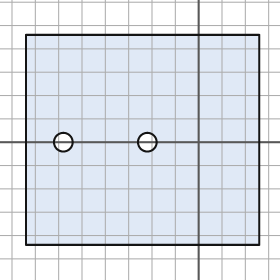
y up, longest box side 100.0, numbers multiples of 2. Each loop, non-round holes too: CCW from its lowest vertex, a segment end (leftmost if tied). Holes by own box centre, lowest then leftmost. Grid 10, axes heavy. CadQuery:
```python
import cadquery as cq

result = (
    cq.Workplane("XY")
    .moveTo(-74.0, -44.0)
    .lineTo(26.0, -44.0)
    .lineTo(26.0, 46.0)
    .lineTo(-74.0, 46.0)
    .close()
    .moveTo(-58.0, 0.0)
    .circle(4.0)
    .moveTo(-22.0, 0.0)
    .circle(4.0)
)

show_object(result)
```